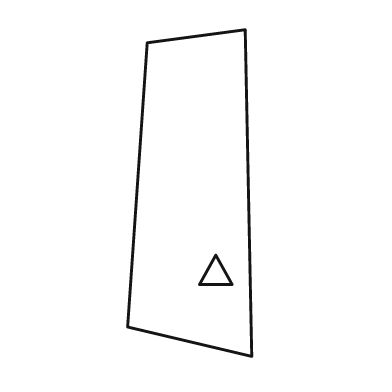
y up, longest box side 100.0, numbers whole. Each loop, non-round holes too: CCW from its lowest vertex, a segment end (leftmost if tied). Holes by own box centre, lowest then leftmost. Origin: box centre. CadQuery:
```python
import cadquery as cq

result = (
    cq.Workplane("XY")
    .moveTo(19.0, -50.0)
    .lineTo(17.0, 50.0)
    .lineTo(-13.0, 46.0)
    .lineTo(-19.0, -41.0)
    .close()
    .moveTo(3.0, -28.0)
    .lineTo(13.0, -28.0)
    .lineTo(8.0, -19.0)
    .close()
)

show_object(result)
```